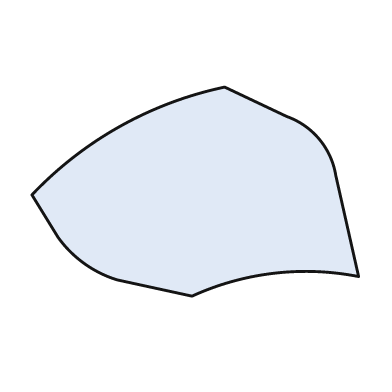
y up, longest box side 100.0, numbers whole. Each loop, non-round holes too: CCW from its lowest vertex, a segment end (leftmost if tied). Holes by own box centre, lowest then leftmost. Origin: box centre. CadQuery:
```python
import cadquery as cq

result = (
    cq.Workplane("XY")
    .moveTo(-1.0, -32.0)
    .threePointArc((24.0, -25.0), (50.0, -26.0))
    .lineTo(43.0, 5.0)
    .threePointArc((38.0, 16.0), (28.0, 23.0))
    .lineTo(9.0, 32.0)
    .threePointArc((-23.0, 20.0), (-50.0, -1.0))
    .lineTo(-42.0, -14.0)
    .threePointArc((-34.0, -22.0), (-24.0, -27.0))
    .close()
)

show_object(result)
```